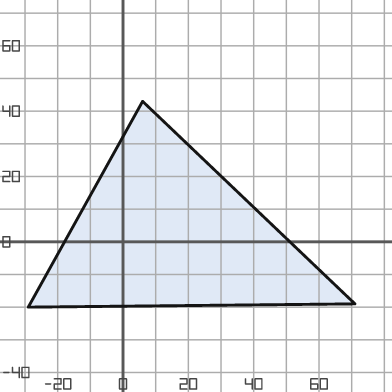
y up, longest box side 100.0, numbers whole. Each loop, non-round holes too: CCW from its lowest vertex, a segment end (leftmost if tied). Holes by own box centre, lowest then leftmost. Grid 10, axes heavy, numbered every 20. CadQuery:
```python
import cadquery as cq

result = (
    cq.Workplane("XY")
    .moveTo(-29.0, -20.0)
    .lineTo(71.0, -19.0)
    .lineTo(6.0, 43.0)
    .close()
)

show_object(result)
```